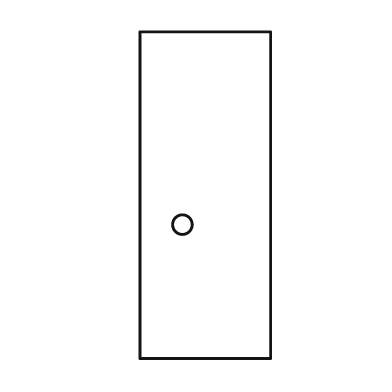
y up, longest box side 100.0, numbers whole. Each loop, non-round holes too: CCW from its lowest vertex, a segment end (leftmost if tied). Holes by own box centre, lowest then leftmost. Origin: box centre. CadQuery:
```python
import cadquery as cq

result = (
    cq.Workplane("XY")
    .moveTo(-20.0, -50.0)
    .lineTo(20.0, -50.0)
    .lineTo(20.0, 50.0)
    .lineTo(-20.0, 50.0)
    .close()
    .moveTo(-7.0, -9.0)
    .circle(3.0)
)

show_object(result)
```